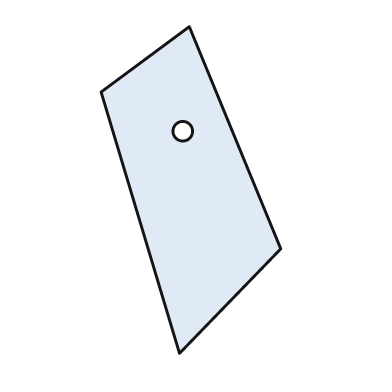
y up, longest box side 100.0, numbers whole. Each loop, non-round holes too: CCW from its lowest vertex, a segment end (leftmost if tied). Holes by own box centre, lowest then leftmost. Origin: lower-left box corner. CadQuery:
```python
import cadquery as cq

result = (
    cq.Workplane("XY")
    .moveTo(24.0, 0.0)
    .lineTo(55.0, 32.0)
    .lineTo(27.0, 100.0)
    .lineTo(0.0, 80.0)
    .close()
    .moveTo(25.0, 68.0)
    .circle(3.0)
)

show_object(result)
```